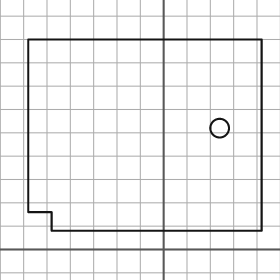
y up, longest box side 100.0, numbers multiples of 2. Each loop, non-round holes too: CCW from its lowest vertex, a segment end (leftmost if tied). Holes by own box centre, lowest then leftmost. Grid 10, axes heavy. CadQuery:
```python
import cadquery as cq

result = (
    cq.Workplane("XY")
    .moveTo(-48.0, 8.0)
    .lineTo(42.0, 8.0)
    .lineTo(42.0, 90.0)
    .lineTo(-58.0, 90.0)
    .lineTo(-58.0, 16.0)
    .lineTo(-48.0, 16.0)
    .close()
    .moveTo(24.0, 52.0)
    .circle(4.0)
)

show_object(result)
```